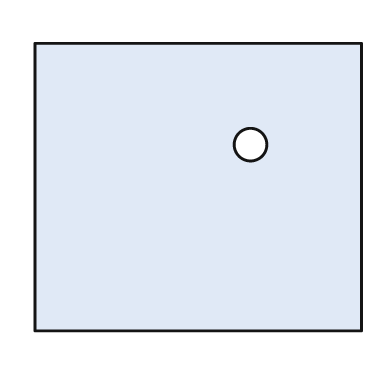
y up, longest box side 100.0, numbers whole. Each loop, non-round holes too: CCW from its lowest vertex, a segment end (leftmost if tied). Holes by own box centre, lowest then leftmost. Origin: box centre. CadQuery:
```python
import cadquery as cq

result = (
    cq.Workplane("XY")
    .moveTo(-50.0, -44.0)
    .lineTo(50.0, -44.0)
    .lineTo(50.0, 44.0)
    .lineTo(-50.0, 44.0)
    .close()
    .moveTo(16.0, 13.0)
    .circle(5.0)
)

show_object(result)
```